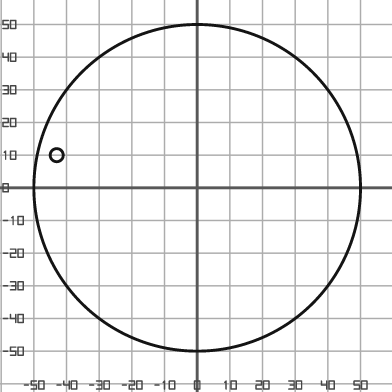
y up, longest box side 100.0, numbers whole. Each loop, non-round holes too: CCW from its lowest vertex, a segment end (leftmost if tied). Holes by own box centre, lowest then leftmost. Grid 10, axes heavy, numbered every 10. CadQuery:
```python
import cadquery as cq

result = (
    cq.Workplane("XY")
    .moveTo(0.0, 0.0)
    .circle(50.0)
    .moveTo(-43.0, 10.0)
    .circle(2.0)
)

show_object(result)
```